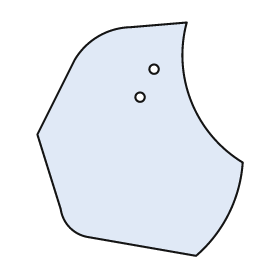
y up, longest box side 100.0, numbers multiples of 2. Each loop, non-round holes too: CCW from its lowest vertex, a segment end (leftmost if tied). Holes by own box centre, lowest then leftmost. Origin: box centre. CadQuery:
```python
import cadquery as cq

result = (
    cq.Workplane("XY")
    .moveTo(24.0, -50.0)
    .threePointArc((38.0, -32.0), (44.0, -10.0))
    .threePointArc((22.0, 16.0), (20.0, 50.0))
    .lineTo(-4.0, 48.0)
    .threePointArc((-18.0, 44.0), (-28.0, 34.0))
    .lineTo(-44.0, 2.0)
    .lineTo(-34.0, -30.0)
    .threePointArc((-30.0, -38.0), (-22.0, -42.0))
    .close()
    .moveTo(0.0, 18.0)
    .circle(2.0)
    .moveTo(6.0, 30.0)
    .circle(2.0)
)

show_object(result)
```